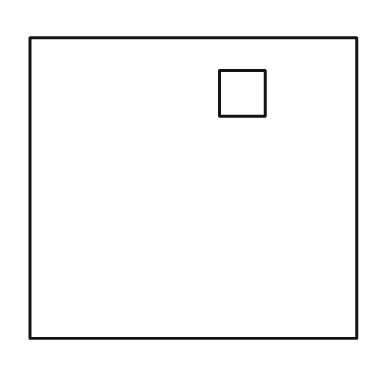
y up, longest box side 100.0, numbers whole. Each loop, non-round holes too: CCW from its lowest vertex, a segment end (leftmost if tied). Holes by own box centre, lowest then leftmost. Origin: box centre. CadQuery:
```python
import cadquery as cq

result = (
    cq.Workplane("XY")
    .moveTo(-50.0, -46.0)
    .lineTo(50.0, -46.0)
    .lineTo(50.0, 46.0)
    .lineTo(-50.0, 46.0)
    .close()
    .moveTo(8.0, 22.0)
    .lineTo(22.0, 22.0)
    .lineTo(22.0, 36.0)
    .lineTo(8.0, 36.0)
    .close()
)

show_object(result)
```